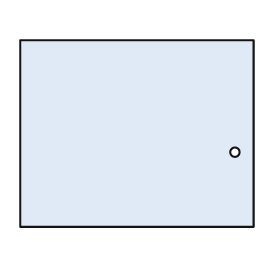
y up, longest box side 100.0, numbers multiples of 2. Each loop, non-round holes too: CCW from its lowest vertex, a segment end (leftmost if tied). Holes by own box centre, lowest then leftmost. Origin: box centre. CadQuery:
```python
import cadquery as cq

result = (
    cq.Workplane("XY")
    .moveTo(-50.0, -40.0)
    .lineTo(50.0, -40.0)
    .lineTo(50.0, 40.0)
    .lineTo(-50.0, 40.0)
    .close()
    .moveTo(42.0, -8.0)
    .circle(2.0)
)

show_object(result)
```